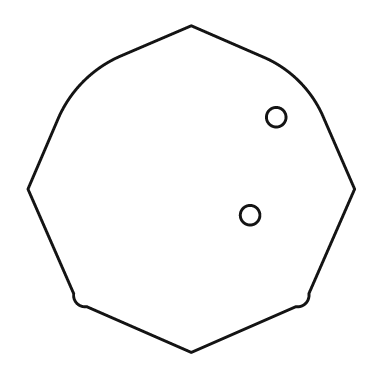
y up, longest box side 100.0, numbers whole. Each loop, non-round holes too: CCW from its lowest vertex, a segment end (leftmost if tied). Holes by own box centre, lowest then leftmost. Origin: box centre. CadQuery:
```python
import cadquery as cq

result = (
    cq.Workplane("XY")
    .moveTo(0.0, -50.0)
    .lineTo(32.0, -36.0)
    .threePointArc((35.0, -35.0), (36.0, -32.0))
    .lineTo(50.0, 0.0)
    .lineTo(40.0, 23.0)
    .threePointArc((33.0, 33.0), (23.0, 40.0))
    .lineTo(0.0, 50.0)
    .lineTo(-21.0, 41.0)
    .threePointArc((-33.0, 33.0), (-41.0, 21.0))
    .lineTo(-50.0, 0.0)
    .lineTo(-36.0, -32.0)
    .threePointArc((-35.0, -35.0), (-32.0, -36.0))
    .close()
    .moveTo(18.0, -8.0)
    .circle(3.0)
    .moveTo(26.0, 22.0)
    .circle(3.0)
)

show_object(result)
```